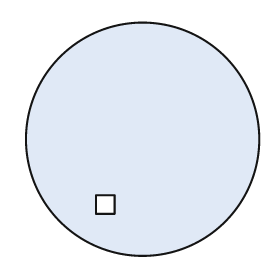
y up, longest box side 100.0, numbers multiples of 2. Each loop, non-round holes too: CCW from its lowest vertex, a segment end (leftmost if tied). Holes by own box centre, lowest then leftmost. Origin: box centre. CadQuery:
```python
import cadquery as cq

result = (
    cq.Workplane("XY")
    .moveTo(0.0, 0.0)
    .circle(50.0)
    .moveTo(-20.0, -32.0)
    .lineTo(-12.0, -32.0)
    .lineTo(-12.0, -24.0)
    .lineTo(-20.0, -24.0)
    .close()
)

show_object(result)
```